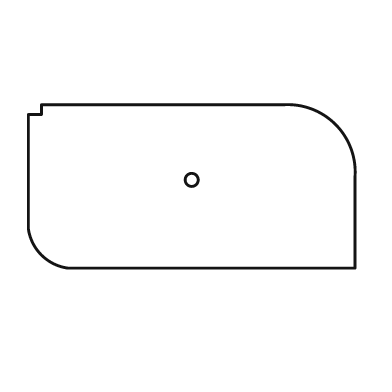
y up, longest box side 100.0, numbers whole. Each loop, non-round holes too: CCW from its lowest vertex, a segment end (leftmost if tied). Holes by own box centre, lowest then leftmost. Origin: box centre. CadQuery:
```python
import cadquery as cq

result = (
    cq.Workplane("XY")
    .moveTo(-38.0, -25.0)
    .lineTo(50.0, -25.0)
    .lineTo(50.0, 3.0)
    .threePointArc((44.0, 19.0), (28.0, 25.0))
    .lineTo(-46.0, 25.0)
    .lineTo(-46.0, 22.0)
    .lineTo(-50.0, 22.0)
    .lineTo(-50.0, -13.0)
    .threePointArc((-46.0, -21.0), (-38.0, -25.0))
    .close()
    .moveTo(0.0, 2.0)
    .circle(2.0)
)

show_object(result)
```